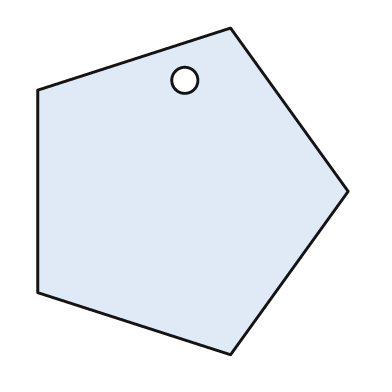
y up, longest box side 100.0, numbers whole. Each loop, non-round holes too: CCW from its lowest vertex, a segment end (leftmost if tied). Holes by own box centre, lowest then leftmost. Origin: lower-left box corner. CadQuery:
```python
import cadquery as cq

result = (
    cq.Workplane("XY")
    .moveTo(59.0, 0.0)
    .lineTo(95.0, 50.0)
    .lineTo(59.0, 100.0)
    .lineTo(0.0, 81.0)
    .lineTo(0.0, 19.0)
    .close()
    .moveTo(45.0, 84.0)
    .circle(4.0)
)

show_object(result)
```